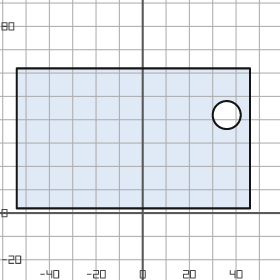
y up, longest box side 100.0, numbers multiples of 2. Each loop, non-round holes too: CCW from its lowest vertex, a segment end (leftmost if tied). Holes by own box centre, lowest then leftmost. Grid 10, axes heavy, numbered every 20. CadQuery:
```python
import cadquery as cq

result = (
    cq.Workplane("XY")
    .moveTo(-54.0, 2.0)
    .lineTo(46.0, 2.0)
    .lineTo(46.0, 62.0)
    .lineTo(-54.0, 62.0)
    .close()
    .moveTo(36.0, 42.0)
    .circle(6.0)
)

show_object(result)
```